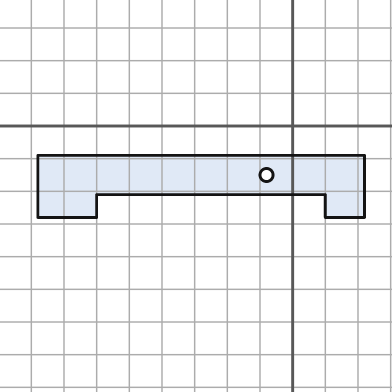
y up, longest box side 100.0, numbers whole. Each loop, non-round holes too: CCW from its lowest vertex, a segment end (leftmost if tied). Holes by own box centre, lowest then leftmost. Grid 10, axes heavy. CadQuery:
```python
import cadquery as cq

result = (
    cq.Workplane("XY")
    .moveTo(-78.0, -28.0)
    .lineTo(-60.0, -28.0)
    .lineTo(-60.0, -21.0)
    .lineTo(10.0, -21.0)
    .lineTo(10.0, -28.0)
    .lineTo(22.0, -28.0)
    .lineTo(22.0, -9.0)
    .lineTo(-78.0, -9.0)
    .close()
    .moveTo(-8.0, -15.0)
    .circle(2.0)
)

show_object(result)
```